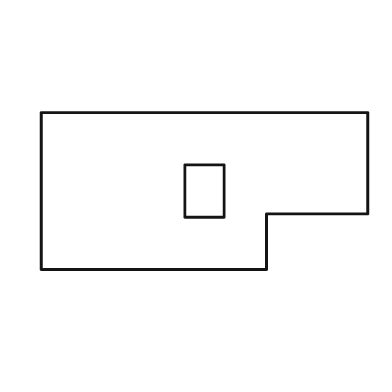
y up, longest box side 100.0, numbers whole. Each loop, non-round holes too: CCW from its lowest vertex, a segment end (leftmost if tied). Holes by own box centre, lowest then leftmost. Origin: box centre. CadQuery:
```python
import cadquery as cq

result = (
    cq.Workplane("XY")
    .moveTo(-50.0, -24.0)
    .lineTo(19.0, -24.0)
    .lineTo(19.0, -7.0)
    .lineTo(50.0, -7.0)
    .lineTo(50.0, 24.0)
    .lineTo(-50.0, 24.0)
    .close()
    .moveTo(-6.0, -8.0)
    .lineTo(6.0, -8.0)
    .lineTo(6.0, 8.0)
    .lineTo(-6.0, 8.0)
    .close()
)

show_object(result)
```